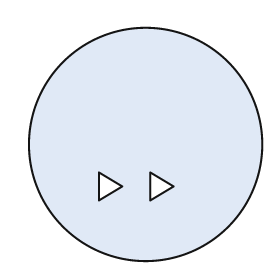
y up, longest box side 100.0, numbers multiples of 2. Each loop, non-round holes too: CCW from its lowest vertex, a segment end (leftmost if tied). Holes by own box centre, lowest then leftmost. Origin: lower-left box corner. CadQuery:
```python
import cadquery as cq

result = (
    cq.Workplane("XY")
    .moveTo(50.0, 50.0)
    .circle(50.0)
    .moveTo(30.0, 26.0)
    .lineTo(40.0, 32.0)
    .lineTo(30.0, 38.0)
    .close()
    .moveTo(52.0, 26.0)
    .lineTo(62.0, 32.0)
    .lineTo(52.0, 38.0)
    .close()
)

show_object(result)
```